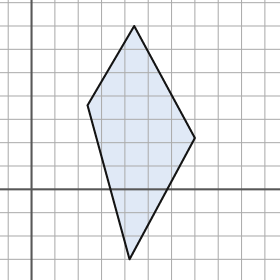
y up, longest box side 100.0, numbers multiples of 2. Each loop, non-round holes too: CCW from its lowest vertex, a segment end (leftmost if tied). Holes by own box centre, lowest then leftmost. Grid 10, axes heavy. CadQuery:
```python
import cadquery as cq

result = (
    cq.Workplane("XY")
    .moveTo(42.0, -30.0)
    .lineTo(70.0, 22.0)
    .lineTo(44.0, 70.0)
    .lineTo(24.0, 36.0)
    .close()
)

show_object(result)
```